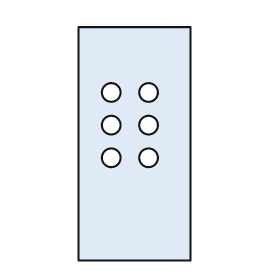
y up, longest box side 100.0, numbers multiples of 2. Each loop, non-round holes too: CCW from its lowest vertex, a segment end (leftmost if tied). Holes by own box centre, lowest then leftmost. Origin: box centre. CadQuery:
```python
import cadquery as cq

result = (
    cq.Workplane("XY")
    .moveTo(-24.0, -50.0)
    .lineTo(24.0, -50.0)
    .lineTo(24.0, 50.0)
    .lineTo(-24.0, 50.0)
    .close()
    .moveTo(-10.0, -6.0)
    .circle(4.0)
    .moveTo(6.0, -6.0)
    .circle(4.0)
    .moveTo(-10.0, 8.0)
    .circle(4.0)
    .moveTo(6.0, 8.0)
    .circle(4.0)
    .moveTo(-10.0, 22.0)
    .circle(4.0)
    .moveTo(6.0, 22.0)
    .circle(4.0)
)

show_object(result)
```